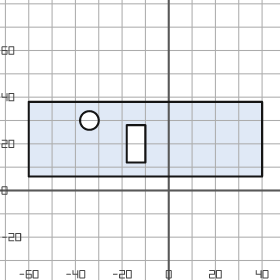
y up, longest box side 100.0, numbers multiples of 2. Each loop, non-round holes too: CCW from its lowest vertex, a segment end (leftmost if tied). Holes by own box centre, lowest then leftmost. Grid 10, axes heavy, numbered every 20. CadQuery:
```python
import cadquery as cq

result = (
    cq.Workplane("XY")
    .moveTo(-60.0, 6.0)
    .lineTo(40.0, 6.0)
    .lineTo(40.0, 38.0)
    .lineTo(-60.0, 38.0)
    .close()
    .moveTo(-18.0, 12.0)
    .lineTo(-10.0, 12.0)
    .lineTo(-10.0, 28.0)
    .lineTo(-18.0, 28.0)
    .close()
    .moveTo(-34.0, 30.0)
    .circle(4.0)
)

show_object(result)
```